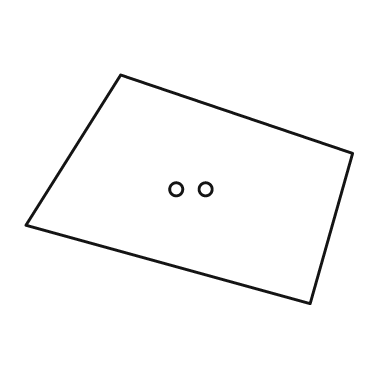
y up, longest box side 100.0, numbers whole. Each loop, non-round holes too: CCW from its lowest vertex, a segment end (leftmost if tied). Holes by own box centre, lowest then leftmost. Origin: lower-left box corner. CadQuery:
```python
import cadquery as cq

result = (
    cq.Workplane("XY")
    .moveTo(87.0, 0.0)
    .lineTo(100.0, 46.0)
    .lineTo(29.0, 70.0)
    .lineTo(0.0, 24.0)
    .close()
    .moveTo(46.0, 35.0)
    .circle(2.0)
    .moveTo(55.0, 35.0)
    .circle(2.0)
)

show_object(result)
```